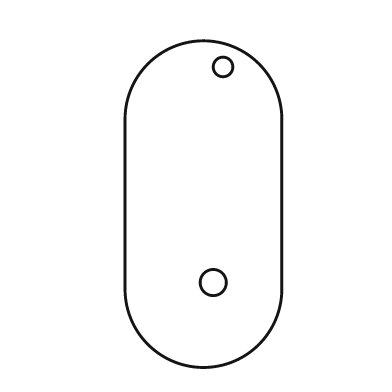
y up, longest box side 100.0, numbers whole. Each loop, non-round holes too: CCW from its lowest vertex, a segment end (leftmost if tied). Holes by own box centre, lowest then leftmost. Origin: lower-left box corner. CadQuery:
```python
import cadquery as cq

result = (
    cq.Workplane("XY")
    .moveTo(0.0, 24.0)
    .threePointArc((24.0, 0.0), (48.0, 24.0))
    .lineTo(48.0, 76.0)
    .threePointArc((24.0, 100.0), (0.0, 76.0))
    .close()
    .moveTo(27.0, 26.0)
    .circle(4.0)
    .moveTo(30.0, 92.0)
    .circle(3.0)
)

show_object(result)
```